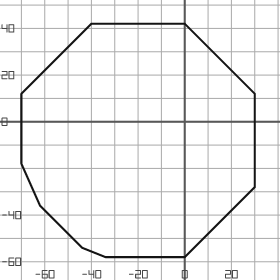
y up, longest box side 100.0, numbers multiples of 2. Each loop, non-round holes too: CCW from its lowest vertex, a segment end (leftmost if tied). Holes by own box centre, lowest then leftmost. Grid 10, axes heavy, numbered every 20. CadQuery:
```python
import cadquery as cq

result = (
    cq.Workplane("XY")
    .moveTo(-34.0, -58.0)
    .lineTo(0.0, -58.0)
    .lineTo(30.0, -28.0)
    .lineTo(30.0, 12.0)
    .lineTo(0.0, 42.0)
    .lineTo(-40.0, 42.0)
    .lineTo(-70.0, 12.0)
    .lineTo(-70.0, -18.0)
    .lineTo(-62.0, -36.0)
    .lineTo(-44.0, -54.0)
    .close()
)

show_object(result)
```